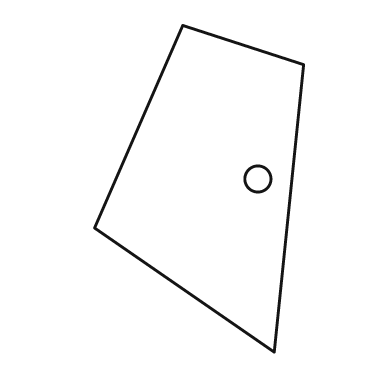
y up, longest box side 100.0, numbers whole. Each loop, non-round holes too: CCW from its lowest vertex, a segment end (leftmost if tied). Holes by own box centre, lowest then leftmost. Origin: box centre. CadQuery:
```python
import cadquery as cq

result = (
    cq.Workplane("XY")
    .moveTo(23.0, -50.0)
    .lineTo(32.0, 38.0)
    .lineTo(-5.0, 50.0)
    .lineTo(-32.0, -12.0)
    .close()
    .moveTo(18.0, 3.0)
    .circle(4.0)
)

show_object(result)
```